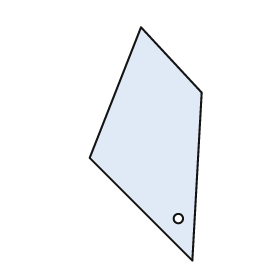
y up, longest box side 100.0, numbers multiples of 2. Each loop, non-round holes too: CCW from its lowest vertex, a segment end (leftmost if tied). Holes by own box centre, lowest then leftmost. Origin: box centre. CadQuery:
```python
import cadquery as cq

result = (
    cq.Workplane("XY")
    .moveTo(20.0, -50.0)
    .lineTo(24.0, 22.0)
    .lineTo(-2.0, 50.0)
    .lineTo(-24.0, -6.0)
    .close()
    .moveTo(14.0, -32.0)
    .circle(2.0)
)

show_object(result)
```